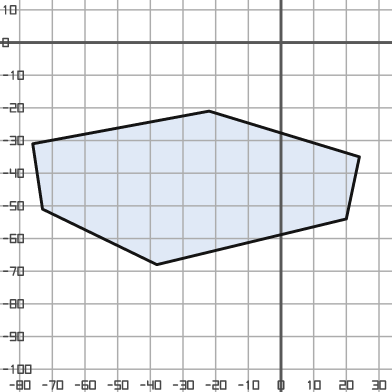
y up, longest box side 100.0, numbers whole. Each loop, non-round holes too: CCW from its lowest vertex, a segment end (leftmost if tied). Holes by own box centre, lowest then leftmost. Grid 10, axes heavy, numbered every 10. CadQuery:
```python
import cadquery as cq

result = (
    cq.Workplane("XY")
    .moveTo(-38.0, -68.0)
    .lineTo(20.0, -54.0)
    .lineTo(24.0, -35.0)
    .lineTo(-22.0, -21.0)
    .lineTo(-76.0, -31.0)
    .lineTo(-73.0, -51.0)
    .close()
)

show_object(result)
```